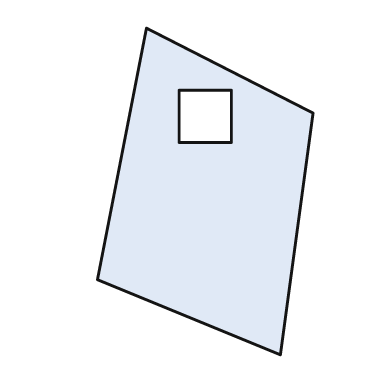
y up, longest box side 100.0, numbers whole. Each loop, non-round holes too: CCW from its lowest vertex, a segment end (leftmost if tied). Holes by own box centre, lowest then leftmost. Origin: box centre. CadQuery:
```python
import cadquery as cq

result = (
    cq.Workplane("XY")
    .moveTo(23.0, -50.0)
    .lineTo(33.0, 24.0)
    .lineTo(-18.0, 50.0)
    .lineTo(-33.0, -27.0)
    .close()
    .moveTo(-8.0, 15.0)
    .lineTo(8.0, 15.0)
    .lineTo(8.0, 31.0)
    .lineTo(-8.0, 31.0)
    .close()
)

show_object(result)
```